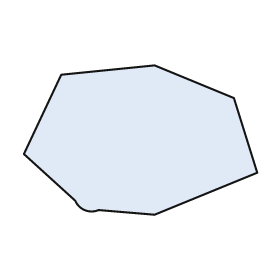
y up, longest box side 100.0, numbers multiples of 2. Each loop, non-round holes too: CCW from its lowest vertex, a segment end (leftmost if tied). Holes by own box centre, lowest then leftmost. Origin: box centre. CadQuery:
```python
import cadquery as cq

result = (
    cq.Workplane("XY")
    .moveTo(6.0, -32.0)
    .lineTo(50.0, -14.0)
    .lineTo(40.0, 18.0)
    .lineTo(6.0, 32.0)
    .lineTo(-34.0, 28.0)
    .lineTo(-50.0, -6.0)
    .lineTo(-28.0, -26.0)
    .threePointArc((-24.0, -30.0), (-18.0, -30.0))
    .close()
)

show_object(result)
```